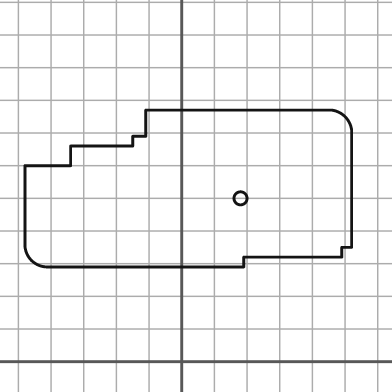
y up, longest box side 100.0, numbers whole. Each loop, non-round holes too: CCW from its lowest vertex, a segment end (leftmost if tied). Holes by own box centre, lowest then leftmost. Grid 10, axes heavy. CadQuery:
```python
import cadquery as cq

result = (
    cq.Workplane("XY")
    .moveTo(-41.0, 29.0)
    .lineTo(19.0, 29.0)
    .lineTo(19.0, 32.0)
    .lineTo(49.0, 32.0)
    .lineTo(49.0, 35.0)
    .lineTo(52.0, 35.0)
    .lineTo(52.0, 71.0)
    .threePointArc((50.0, 75.0), (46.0, 77.0))
    .lineTo(-11.0, 77.0)
    .lineTo(-11.0, 69.0)
    .lineTo(-15.0, 69.0)
    .lineTo(-15.0, 66.0)
    .lineTo(-34.0, 66.0)
    .lineTo(-34.0, 60.0)
    .lineTo(-48.0, 60.0)
    .lineTo(-48.0, 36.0)
    .threePointArc((-46.0, 31.0), (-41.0, 29.0))
    .close()
    .moveTo(18.0, 50.0)
    .circle(2.0)
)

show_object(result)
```